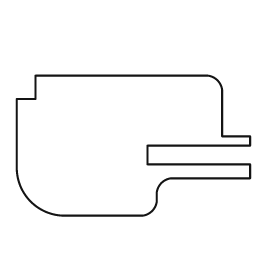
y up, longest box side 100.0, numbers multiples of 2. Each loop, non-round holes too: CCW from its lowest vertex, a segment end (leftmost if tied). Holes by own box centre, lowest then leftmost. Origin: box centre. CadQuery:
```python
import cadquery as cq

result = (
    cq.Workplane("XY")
    .moveTo(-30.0, -30.0)
    .lineTo(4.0, -30.0)
    .threePointArc((8.0, -28.0), (10.0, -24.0))
    .lineTo(10.0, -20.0)
    .threePointArc((12.0, -16.0), (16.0, -14.0))
    .lineTo(50.0, -14.0)
    .lineTo(50.0, -8.0)
    .lineTo(6.0, -8.0)
    .lineTo(6.0, 0.0)
    .lineTo(50.0, 0.0)
    .lineTo(50.0, 4.0)
    .lineTo(38.0, 4.0)
    .lineTo(38.0, 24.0)
    .threePointArc((36.0, 28.0), (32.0, 30.0))
    .lineTo(-42.0, 30.0)
    .lineTo(-42.0, 20.0)
    .lineTo(-50.0, 20.0)
    .lineTo(-50.0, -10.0)
    .threePointArc((-44.0, -24.0), (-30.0, -30.0))
    .close()
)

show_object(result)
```